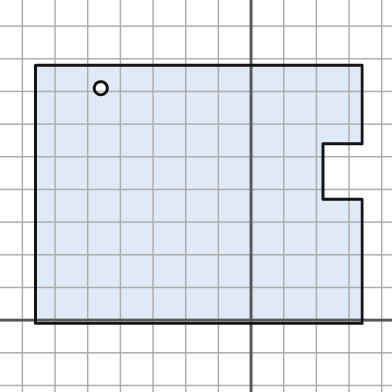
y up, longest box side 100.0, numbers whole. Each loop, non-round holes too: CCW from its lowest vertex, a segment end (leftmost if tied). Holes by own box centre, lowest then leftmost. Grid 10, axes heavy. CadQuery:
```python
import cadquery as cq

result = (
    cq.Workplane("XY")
    .moveTo(-66.0, -1.0)
    .lineTo(34.0, -1.0)
    .lineTo(34.0, 37.0)
    .lineTo(22.0, 37.0)
    .lineTo(22.0, 54.0)
    .lineTo(34.0, 54.0)
    .lineTo(34.0, 78.0)
    .lineTo(-66.0, 78.0)
    .close()
    .moveTo(-46.0, 71.0)
    .circle(2.0)
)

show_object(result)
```